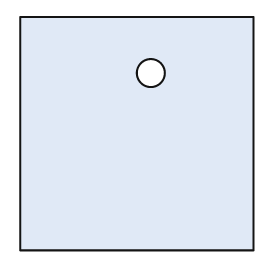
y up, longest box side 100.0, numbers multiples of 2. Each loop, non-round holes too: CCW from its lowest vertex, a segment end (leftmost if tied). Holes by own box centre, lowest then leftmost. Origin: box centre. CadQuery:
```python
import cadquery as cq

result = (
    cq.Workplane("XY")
    .moveTo(-50.0, -50.0)
    .lineTo(50.0, -50.0)
    .lineTo(50.0, 50.0)
    .lineTo(-50.0, 50.0)
    .close()
    .moveTo(6.0, 26.0)
    .circle(6.0)
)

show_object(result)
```